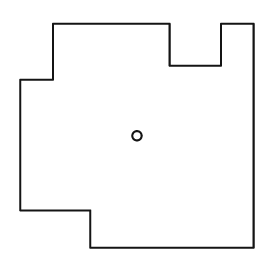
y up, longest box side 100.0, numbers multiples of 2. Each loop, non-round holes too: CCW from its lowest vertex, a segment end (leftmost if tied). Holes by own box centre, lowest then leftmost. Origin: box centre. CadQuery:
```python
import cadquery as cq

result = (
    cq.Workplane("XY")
    .moveTo(-20.0, -48.0)
    .lineTo(50.0, -48.0)
    .lineTo(50.0, 48.0)
    .lineTo(36.0, 48.0)
    .lineTo(36.0, 30.0)
    .lineTo(14.0, 30.0)
    .lineTo(14.0, 48.0)
    .lineTo(-36.0, 48.0)
    .lineTo(-36.0, 24.0)
    .lineTo(-50.0, 24.0)
    .lineTo(-50.0, -32.0)
    .lineTo(-20.0, -32.0)
    .close()
    .moveTo(0.0, 0.0)
    .circle(2.0)
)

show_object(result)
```